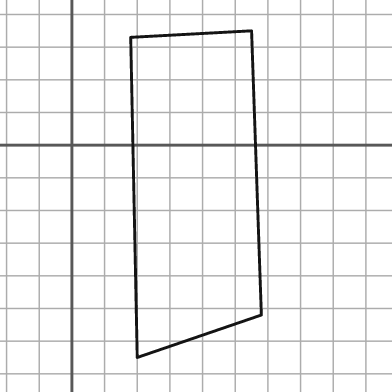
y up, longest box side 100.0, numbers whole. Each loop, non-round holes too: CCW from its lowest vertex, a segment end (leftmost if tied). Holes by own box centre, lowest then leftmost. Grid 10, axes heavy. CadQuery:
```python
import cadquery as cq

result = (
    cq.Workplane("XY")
    .moveTo(20.0, -65.0)
    .lineTo(58.0, -52.0)
    .lineTo(55.0, 35.0)
    .lineTo(18.0, 33.0)
    .close()
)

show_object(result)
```